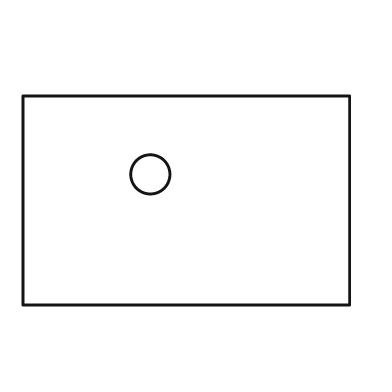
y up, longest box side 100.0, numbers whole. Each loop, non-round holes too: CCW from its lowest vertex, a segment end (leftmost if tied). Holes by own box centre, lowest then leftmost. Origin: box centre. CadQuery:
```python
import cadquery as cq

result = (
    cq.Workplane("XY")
    .moveTo(-50.0, -32.0)
    .lineTo(50.0, -32.0)
    .lineTo(50.0, 32.0)
    .lineTo(-50.0, 32.0)
    .close()
    .moveTo(-11.0, 8.0)
    .circle(6.0)
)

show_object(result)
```